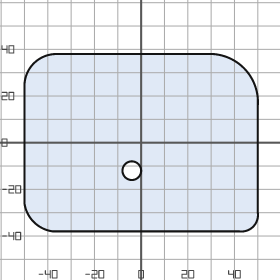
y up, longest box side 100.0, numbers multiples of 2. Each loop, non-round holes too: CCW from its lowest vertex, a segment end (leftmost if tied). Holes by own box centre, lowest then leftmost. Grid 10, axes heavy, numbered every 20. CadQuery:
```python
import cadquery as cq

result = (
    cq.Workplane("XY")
    .moveTo(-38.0, -38.0)
    .lineTo(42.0, -38.0)
    .threePointArc((48.0, -36.0), (50.0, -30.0))
    .lineTo(50.0, 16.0)
    .threePointArc((44.0, 32.0), (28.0, 38.0))
    .lineTo(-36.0, 38.0)
    .threePointArc((-46.0, 34.0), (-50.0, 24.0))
    .lineTo(-50.0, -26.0)
    .threePointArc((-46.0, -34.0), (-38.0, -38.0))
    .close()
    .moveTo(-4.0, -12.0)
    .circle(4.0)
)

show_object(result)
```